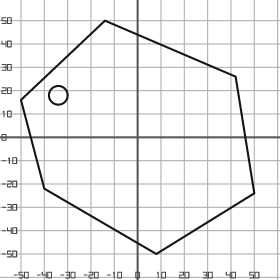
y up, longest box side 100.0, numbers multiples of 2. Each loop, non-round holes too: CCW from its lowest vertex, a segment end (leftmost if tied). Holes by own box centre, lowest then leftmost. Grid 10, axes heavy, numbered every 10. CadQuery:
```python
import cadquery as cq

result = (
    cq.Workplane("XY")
    .moveTo(8.0, -50.0)
    .lineTo(50.0, -24.0)
    .lineTo(42.0, 26.0)
    .lineTo(-14.0, 50.0)
    .lineTo(-50.0, 16.0)
    .lineTo(-40.0, -22.0)
    .close()
    .moveTo(-34.0, 18.0)
    .circle(4.0)
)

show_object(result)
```